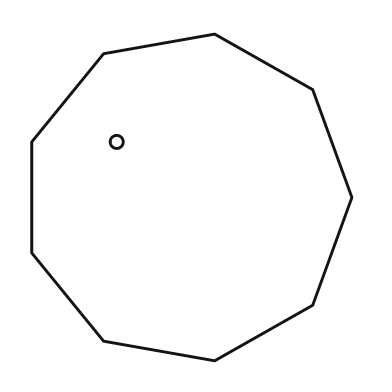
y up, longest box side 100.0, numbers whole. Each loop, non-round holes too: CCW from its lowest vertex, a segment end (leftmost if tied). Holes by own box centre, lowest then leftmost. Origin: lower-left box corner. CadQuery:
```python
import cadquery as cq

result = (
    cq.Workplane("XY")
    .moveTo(56.0, 0.0)
    .lineTo(86.0, 17.0)
    .lineTo(98.0, 50.0)
    .lineTo(86.0, 83.0)
    .lineTo(56.0, 100.0)
    .lineTo(22.0, 94.0)
    .lineTo(0.0, 67.0)
    .lineTo(0.0, 33.0)
    .lineTo(22.0, 6.0)
    .close()
    .moveTo(26.0, 67.0)
    .circle(2.0)
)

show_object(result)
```